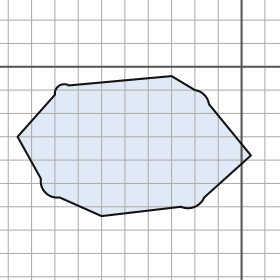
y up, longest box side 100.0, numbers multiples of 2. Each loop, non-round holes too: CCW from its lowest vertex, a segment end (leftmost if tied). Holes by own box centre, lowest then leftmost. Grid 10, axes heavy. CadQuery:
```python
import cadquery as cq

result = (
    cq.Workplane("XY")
    .moveTo(-60.0, -64.0)
    .lineTo(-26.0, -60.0)
    .threePointArc((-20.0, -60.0), (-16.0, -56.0))
    .lineTo(4.0, -38.0)
    .lineTo(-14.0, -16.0)
    .threePointArc((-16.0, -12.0), (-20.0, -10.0))
    .lineTo(-30.0, -4.0)
    .lineTo(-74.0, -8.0)
    .threePointArc((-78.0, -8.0), (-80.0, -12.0))
    .lineTo(-96.0, -30.0)
    .lineTo(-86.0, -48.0)
    .threePointArc((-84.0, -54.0), (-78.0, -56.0))
    .close()
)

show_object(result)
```